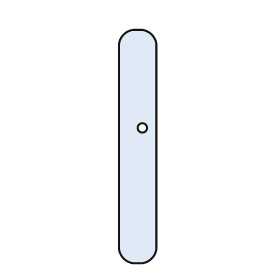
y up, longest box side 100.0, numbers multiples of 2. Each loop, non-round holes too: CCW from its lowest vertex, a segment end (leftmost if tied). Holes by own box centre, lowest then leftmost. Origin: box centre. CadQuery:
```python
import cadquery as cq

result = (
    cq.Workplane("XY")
    .moveTo(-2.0, -50.0)
    .lineTo(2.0, -50.0)
    .threePointArc((6.0, -48.0), (8.0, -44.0))
    .lineTo(8.0, 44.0)
    .threePointArc((6.0, 48.0), (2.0, 50.0))
    .lineTo(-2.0, 50.0)
    .threePointArc((-6.0, 48.0), (-8.0, 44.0))
    .lineTo(-8.0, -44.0)
    .threePointArc((-6.0, -48.0), (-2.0, -50.0))
    .close()
    .moveTo(2.0, 8.0)
    .circle(2.0)
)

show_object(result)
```